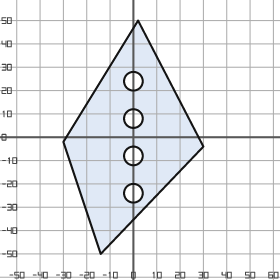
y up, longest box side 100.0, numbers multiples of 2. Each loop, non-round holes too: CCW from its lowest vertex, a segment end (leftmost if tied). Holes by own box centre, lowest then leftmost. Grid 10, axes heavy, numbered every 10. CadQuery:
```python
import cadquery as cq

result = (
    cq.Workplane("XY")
    .moveTo(-14.0, -50.0)
    .lineTo(30.0, -4.0)
    .lineTo(2.0, 50.0)
    .lineTo(-30.0, -2.0)
    .close()
    .moveTo(0.0, -24.0)
    .circle(4.0)
    .moveTo(0.0, -8.0)
    .circle(4.0)
    .moveTo(0.0, 8.0)
    .circle(4.0)
    .moveTo(0.0, 24.0)
    .circle(4.0)
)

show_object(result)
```